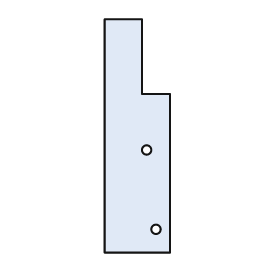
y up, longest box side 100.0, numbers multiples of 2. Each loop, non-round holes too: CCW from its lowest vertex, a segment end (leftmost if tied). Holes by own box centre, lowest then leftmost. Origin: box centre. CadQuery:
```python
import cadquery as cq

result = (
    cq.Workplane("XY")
    .moveTo(-14.0, -50.0)
    .lineTo(14.0, -50.0)
    .lineTo(14.0, 18.0)
    .lineTo(2.0, 18.0)
    .lineTo(2.0, 50.0)
    .lineTo(-14.0, 50.0)
    .close()
    .moveTo(8.0, -40.0)
    .circle(2.0)
    .moveTo(4.0, -6.0)
    .circle(2.0)
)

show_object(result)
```